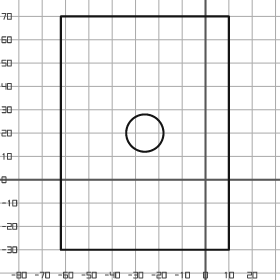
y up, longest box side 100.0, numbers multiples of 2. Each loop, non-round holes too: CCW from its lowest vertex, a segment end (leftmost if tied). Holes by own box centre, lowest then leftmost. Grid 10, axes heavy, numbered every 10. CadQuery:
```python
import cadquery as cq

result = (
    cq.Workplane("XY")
    .moveTo(-62.0, -30.0)
    .lineTo(10.0, -30.0)
    .lineTo(10.0, 70.0)
    .lineTo(-62.0, 70.0)
    .close()
    .moveTo(-26.0, 20.0)
    .circle(8.0)
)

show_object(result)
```